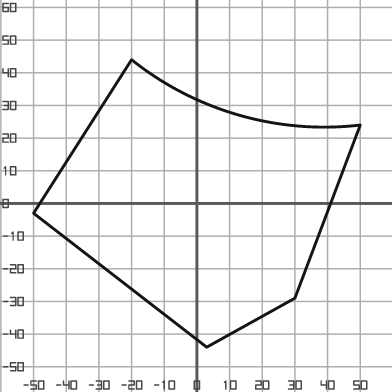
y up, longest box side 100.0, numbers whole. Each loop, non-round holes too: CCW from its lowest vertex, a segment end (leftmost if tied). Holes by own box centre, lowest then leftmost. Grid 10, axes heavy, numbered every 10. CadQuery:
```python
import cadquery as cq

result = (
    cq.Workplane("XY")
    .moveTo(3.0, -44.0)
    .lineTo(30.0, -29.0)
    .lineTo(50.0, 24.0)
    .threePointArc((13.0, 27.0), (-20.0, 44.0))
    .lineTo(-50.0, -3.0)
    .close()
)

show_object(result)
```